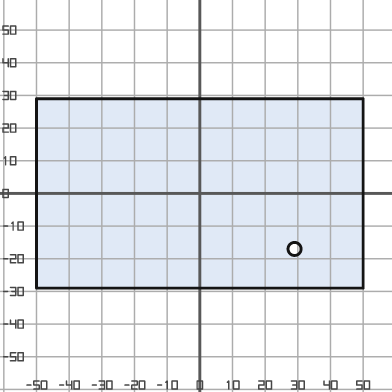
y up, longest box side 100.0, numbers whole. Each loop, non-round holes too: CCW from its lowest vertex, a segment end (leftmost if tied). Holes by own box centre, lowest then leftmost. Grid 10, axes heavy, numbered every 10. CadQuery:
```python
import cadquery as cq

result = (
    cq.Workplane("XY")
    .moveTo(-50.0, -29.0)
    .lineTo(50.0, -29.0)
    .lineTo(50.0, 29.0)
    .lineTo(-50.0, 29.0)
    .close()
    .moveTo(29.0, -17.0)
    .circle(2.0)
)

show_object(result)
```